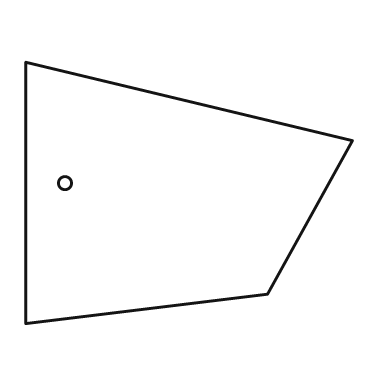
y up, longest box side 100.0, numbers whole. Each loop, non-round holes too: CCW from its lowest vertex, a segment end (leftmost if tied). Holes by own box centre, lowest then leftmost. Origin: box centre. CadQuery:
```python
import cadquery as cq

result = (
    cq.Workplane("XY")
    .moveTo(-50.0, -40.0)
    .lineTo(24.0, -31.0)
    .lineTo(50.0, 16.0)
    .lineTo(-50.0, 40.0)
    .close()
    .moveTo(-38.0, 3.0)
    .circle(2.0)
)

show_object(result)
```